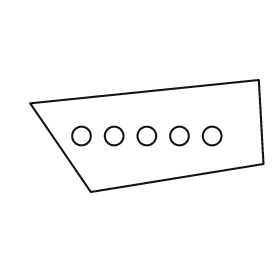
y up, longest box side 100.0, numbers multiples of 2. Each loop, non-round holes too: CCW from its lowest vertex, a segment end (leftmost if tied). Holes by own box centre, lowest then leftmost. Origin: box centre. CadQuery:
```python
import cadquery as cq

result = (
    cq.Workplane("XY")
    .moveTo(-24.0, -24.0)
    .lineTo(50.0, -12.0)
    .lineTo(48.0, 24.0)
    .lineTo(-50.0, 14.0)
    .close()
    .moveTo(-28.0, 0.0)
    .circle(4.0)
    .moveTo(-14.0, 0.0)
    .circle(4.0)
    .moveTo(0.0, 0.0)
    .circle(4.0)
    .moveTo(14.0, 0.0)
    .circle(4.0)
    .moveTo(28.0, 0.0)
    .circle(4.0)
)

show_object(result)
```